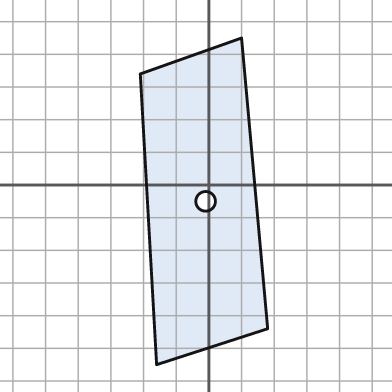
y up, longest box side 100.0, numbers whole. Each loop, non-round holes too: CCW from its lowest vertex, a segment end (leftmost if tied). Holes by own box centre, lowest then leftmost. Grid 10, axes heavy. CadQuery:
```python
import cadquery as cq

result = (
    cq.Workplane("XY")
    .moveTo(-16.0, -55.0)
    .lineTo(18.0, -44.0)
    .lineTo(10.0, 45.0)
    .lineTo(-21.0, 34.0)
    .close()
    .moveTo(-1.0, -5.0)
    .circle(3.0)
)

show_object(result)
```